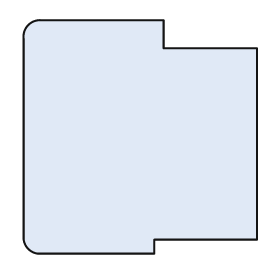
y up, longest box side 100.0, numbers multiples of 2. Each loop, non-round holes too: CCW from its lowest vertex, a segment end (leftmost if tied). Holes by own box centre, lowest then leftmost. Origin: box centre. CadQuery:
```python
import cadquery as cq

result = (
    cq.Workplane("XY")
    .moveTo(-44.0, -50.0)
    .lineTo(6.0, -50.0)
    .lineTo(6.0, -44.0)
    .lineTo(50.0, -44.0)
    .lineTo(50.0, 38.0)
    .lineTo(10.0, 38.0)
    .lineTo(10.0, 50.0)
    .lineTo(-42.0, 50.0)
    .threePointArc((-48.0, 48.0), (-50.0, 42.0))
    .lineTo(-50.0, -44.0)
    .threePointArc((-48.0, -48.0), (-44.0, -50.0))
    .close()
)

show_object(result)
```